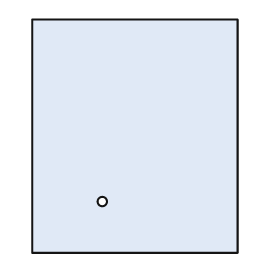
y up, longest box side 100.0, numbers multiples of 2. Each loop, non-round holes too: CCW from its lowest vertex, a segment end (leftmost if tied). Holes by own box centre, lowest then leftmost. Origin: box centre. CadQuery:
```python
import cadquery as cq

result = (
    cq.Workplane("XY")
    .moveTo(-44.0, -50.0)
    .lineTo(44.0, -50.0)
    .lineTo(44.0, 50.0)
    .lineTo(-44.0, 50.0)
    .close()
    .moveTo(-14.0, -28.0)
    .circle(2.0)
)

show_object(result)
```